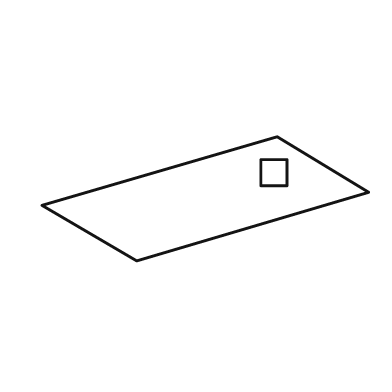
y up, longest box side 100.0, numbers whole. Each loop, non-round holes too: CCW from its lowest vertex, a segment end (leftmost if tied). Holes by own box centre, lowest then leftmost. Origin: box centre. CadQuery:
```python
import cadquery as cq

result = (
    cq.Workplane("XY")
    .moveTo(-21.0, -19.0)
    .lineTo(50.0, 2.0)
    .lineTo(22.0, 19.0)
    .lineTo(-50.0, -2.0)
    .close()
    .moveTo(17.0, 4.0)
    .lineTo(25.0, 4.0)
    .lineTo(25.0, 12.0)
    .lineTo(17.0, 12.0)
    .close()
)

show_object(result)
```